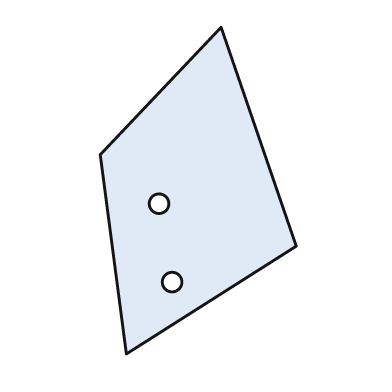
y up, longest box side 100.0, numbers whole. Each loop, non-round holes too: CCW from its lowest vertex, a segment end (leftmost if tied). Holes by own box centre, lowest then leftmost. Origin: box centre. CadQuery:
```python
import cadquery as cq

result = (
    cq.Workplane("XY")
    .moveTo(-22.0, -50.0)
    .lineTo(30.0, -17.0)
    .lineTo(7.0, 50.0)
    .lineTo(-30.0, 11.0)
    .close()
    .moveTo(-8.0, -28.0)
    .circle(3.0)
    .moveTo(-12.0, -4.0)
    .circle(3.0)
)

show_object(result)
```